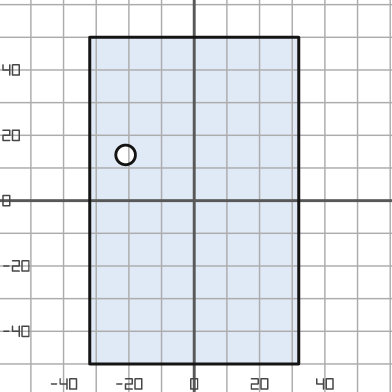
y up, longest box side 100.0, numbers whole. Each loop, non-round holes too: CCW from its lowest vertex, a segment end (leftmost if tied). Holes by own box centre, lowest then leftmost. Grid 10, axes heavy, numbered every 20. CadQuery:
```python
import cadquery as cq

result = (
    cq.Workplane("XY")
    .moveTo(-32.0, -50.0)
    .lineTo(32.0, -50.0)
    .lineTo(32.0, 50.0)
    .lineTo(-32.0, 50.0)
    .close()
    .moveTo(-21.0, 14.0)
    .circle(3.0)
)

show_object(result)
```